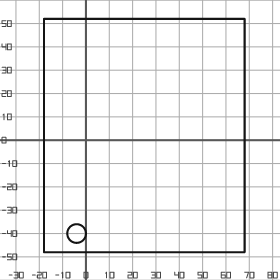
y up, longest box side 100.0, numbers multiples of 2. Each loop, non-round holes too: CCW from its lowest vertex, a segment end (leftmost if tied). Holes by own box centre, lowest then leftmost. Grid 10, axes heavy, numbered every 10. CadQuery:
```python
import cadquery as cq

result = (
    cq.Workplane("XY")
    .moveTo(-18.0, -48.0)
    .lineTo(68.0, -48.0)
    .lineTo(68.0, 52.0)
    .lineTo(-18.0, 52.0)
    .close()
    .moveTo(-4.0, -40.0)
    .circle(4.0)
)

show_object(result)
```